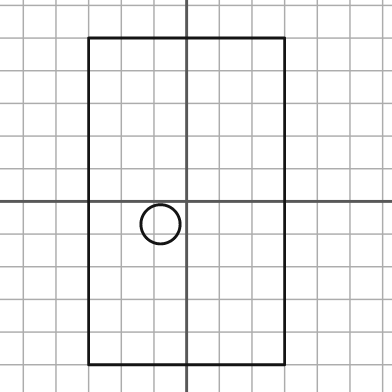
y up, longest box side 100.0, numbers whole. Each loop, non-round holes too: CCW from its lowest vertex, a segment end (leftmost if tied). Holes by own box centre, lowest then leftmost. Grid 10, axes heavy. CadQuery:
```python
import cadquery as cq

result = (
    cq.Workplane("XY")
    .moveTo(-30.0, -50.0)
    .lineTo(30.0, -50.0)
    .lineTo(30.0, 50.0)
    .lineTo(-30.0, 50.0)
    .close()
    .moveTo(-8.0, -7.0)
    .circle(6.0)
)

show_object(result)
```